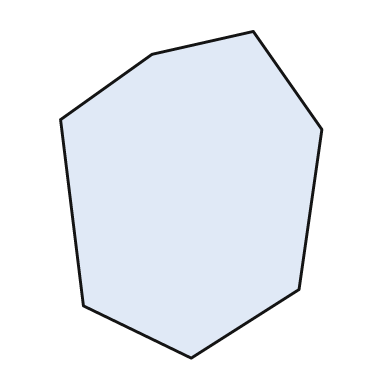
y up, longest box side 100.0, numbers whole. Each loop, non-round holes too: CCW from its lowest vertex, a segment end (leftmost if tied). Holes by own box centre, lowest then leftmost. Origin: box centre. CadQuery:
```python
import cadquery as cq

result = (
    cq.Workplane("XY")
    .moveTo(0.0, -50.0)
    .lineTo(33.0, -29.0)
    .lineTo(40.0, 20.0)
    .lineTo(19.0, 50.0)
    .lineTo(-12.0, 43.0)
    .lineTo(-40.0, 23.0)
    .lineTo(-33.0, -34.0)
    .close()
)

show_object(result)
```